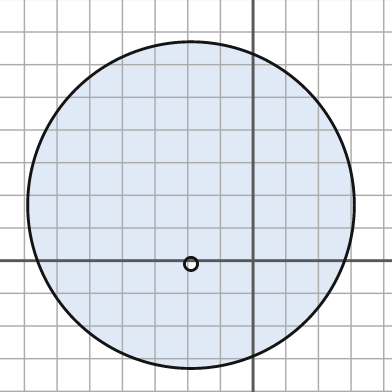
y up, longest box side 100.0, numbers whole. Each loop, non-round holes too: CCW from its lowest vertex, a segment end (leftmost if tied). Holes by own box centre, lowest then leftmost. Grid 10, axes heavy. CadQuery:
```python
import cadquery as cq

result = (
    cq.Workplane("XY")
    .moveTo(-19.0, 17.0)
    .circle(50.0)
    .moveTo(-19.0, -1.0)
    .circle(2.0)
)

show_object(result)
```